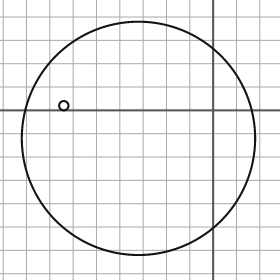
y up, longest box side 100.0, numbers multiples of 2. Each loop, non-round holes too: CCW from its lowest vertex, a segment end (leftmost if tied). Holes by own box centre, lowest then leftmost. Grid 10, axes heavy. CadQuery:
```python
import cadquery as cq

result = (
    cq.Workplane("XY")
    .moveTo(-32.0, -12.0)
    .circle(50.0)
    .moveTo(-64.0, 2.0)
    .circle(2.0)
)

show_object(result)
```